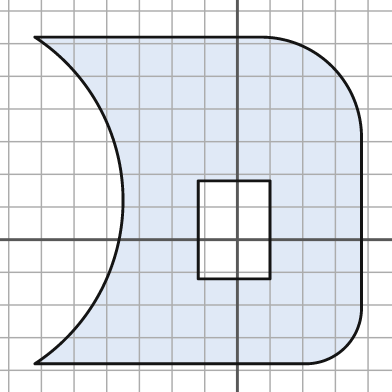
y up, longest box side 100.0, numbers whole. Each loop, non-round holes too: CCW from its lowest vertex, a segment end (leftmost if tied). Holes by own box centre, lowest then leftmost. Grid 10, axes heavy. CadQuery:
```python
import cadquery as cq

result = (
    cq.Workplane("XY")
    .moveTo(-62.0, -38.0)
    .lineTo(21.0, -38.0)
    .threePointArc((33.0, -33.0), (38.0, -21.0))
    .lineTo(38.0, 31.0)
    .threePointArc((29.0, 53.0), (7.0, 62.0))
    .lineTo(-62.0, 62.0)
    .threePointArc((-35.0, 12.0), (-62.0, -38.0))
    .close()
    .moveTo(-12.0, -12.0)
    .lineTo(10.0, -12.0)
    .lineTo(10.0, 18.0)
    .lineTo(-12.0, 18.0)
    .close()
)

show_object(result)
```